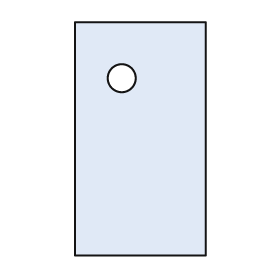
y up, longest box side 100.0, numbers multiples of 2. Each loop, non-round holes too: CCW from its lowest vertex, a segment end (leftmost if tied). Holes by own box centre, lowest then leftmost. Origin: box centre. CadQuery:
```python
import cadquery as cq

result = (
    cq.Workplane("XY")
    .moveTo(-28.0, -50.0)
    .lineTo(28.0, -50.0)
    .lineTo(28.0, 50.0)
    .lineTo(-28.0, 50.0)
    .close()
    .moveTo(-8.0, 26.0)
    .circle(6.0)
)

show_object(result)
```